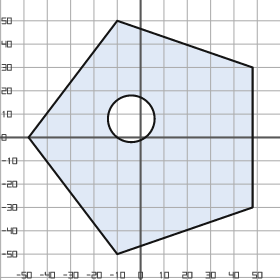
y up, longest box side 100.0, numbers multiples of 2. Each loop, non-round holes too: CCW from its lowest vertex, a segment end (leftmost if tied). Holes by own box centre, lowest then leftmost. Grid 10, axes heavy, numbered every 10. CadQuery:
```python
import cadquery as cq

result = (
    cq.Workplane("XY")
    .moveTo(-10.0, -50.0)
    .lineTo(48.0, -30.0)
    .lineTo(48.0, 30.0)
    .lineTo(-10.0, 50.0)
    .lineTo(-48.0, 0.0)
    .close()
    .moveTo(-4.0, 8.0)
    .circle(10.0)
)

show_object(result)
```